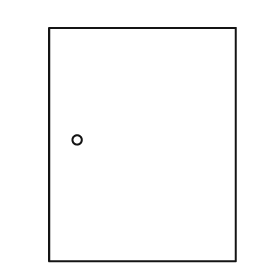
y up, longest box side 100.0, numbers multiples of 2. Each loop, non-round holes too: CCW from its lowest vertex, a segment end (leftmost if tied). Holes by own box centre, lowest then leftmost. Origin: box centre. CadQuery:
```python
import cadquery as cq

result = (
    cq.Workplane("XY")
    .moveTo(-40.0, -50.0)
    .lineTo(40.0, -50.0)
    .lineTo(40.0, 50.0)
    .lineTo(-40.0, 50.0)
    .close()
    .moveTo(-28.0, 2.0)
    .circle(2.0)
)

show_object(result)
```